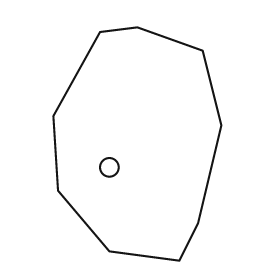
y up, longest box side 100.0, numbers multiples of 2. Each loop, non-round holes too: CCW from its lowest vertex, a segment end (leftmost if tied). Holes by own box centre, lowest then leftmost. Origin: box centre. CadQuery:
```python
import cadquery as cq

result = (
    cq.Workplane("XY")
    .moveTo(18.0, -50.0)
    .lineTo(26.0, -34.0)
    .lineTo(36.0, 8.0)
    .lineTo(28.0, 40.0)
    .lineTo(0.0, 50.0)
    .lineTo(-16.0, 48.0)
    .lineTo(-36.0, 12.0)
    .lineTo(-34.0, -20.0)
    .lineTo(-12.0, -46.0)
    .close()
    .moveTo(-12.0, -10.0)
    .circle(4.0)
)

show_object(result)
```